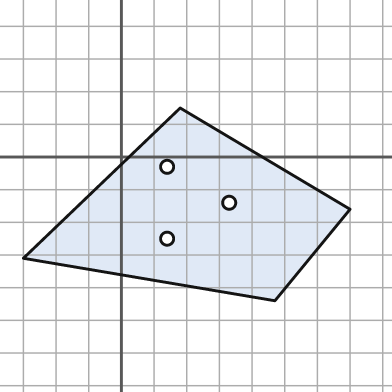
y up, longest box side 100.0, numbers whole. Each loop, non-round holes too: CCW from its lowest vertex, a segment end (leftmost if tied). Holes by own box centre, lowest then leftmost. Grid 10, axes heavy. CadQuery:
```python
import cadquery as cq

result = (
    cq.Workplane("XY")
    .moveTo(47.0, -44.0)
    .lineTo(70.0, -16.0)
    .lineTo(18.0, 15.0)
    .lineTo(-30.0, -31.0)
    .close()
    .moveTo(14.0, -25.0)
    .circle(2.0)
    .moveTo(33.0, -14.0)
    .circle(2.0)
    .moveTo(14.0, -3.0)
    .circle(2.0)
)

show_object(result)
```